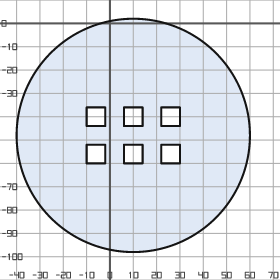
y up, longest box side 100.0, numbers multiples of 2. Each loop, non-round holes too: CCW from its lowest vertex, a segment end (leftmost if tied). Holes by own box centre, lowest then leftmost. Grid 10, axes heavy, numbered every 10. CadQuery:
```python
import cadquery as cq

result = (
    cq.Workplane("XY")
    .moveTo(10.0, -48.0)
    .circle(50.0)
    .moveTo(-10.0, -60.0)
    .lineTo(-2.0, -60.0)
    .lineTo(-2.0, -52.0)
    .lineTo(-10.0, -52.0)
    .close()
    .moveTo(6.0, -60.0)
    .lineTo(14.0, -60.0)
    .lineTo(14.0, -52.0)
    .lineTo(6.0, -52.0)
    .close()
    .moveTo(22.0, -60.0)
    .lineTo(30.0, -60.0)
    .lineTo(30.0, -52.0)
    .lineTo(22.0, -52.0)
    .close()
    .moveTo(-10.0, -44.0)
    .lineTo(-2.0, -44.0)
    .lineTo(-2.0, -36.0)
    .lineTo(-10.0, -36.0)
    .close()
    .moveTo(6.0, -44.0)
    .lineTo(14.0, -44.0)
    .lineTo(14.0, -36.0)
    .lineTo(6.0, -36.0)
    .close()
    .moveTo(22.0, -44.0)
    .lineTo(30.0, -44.0)
    .lineTo(30.0, -36.0)
    .lineTo(22.0, -36.0)
    .close()
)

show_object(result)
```